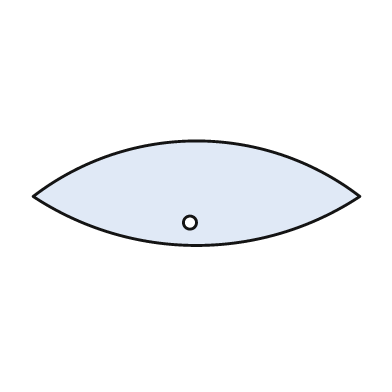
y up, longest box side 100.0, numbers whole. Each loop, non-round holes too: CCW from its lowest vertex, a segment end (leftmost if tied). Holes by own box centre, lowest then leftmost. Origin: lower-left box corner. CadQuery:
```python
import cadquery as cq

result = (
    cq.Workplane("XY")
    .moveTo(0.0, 15.0)
    .threePointArc((50.0, 0.0), (100.0, 15.0))
    .threePointArc((50.0, 32.0), (0.0, 15.0))
    .close()
    .moveTo(48.0, 7.0)
    .circle(2.0)
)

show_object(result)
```